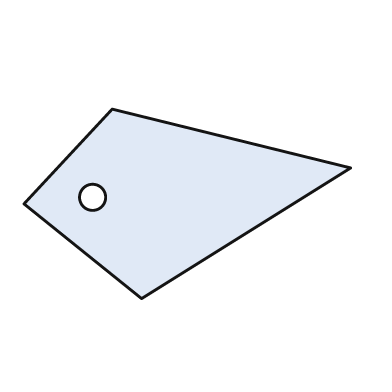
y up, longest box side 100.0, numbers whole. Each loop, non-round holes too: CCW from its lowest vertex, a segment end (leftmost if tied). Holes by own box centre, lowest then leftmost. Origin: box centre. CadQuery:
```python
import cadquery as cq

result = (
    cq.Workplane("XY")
    .moveTo(-14.0, -29.0)
    .lineTo(50.0, 11.0)
    .lineTo(-23.0, 29.0)
    .lineTo(-50.0, 0.0)
    .close()
    .moveTo(-29.0, 2.0)
    .circle(4.0)
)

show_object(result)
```